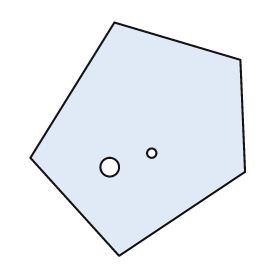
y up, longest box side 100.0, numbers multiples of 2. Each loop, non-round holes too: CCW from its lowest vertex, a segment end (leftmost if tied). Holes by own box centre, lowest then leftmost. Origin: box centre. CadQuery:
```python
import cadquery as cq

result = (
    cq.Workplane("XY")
    .moveTo(-8.0, -50.0)
    .lineTo(46.0, -14.0)
    .lineTo(44.0, 34.0)
    .lineTo(-10.0, 50.0)
    .lineTo(-46.0, -8.0)
    .close()
    .moveTo(-12.0, -12.0)
    .circle(4.0)
    .moveTo(6.0, -6.0)
    .circle(2.0)
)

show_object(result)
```